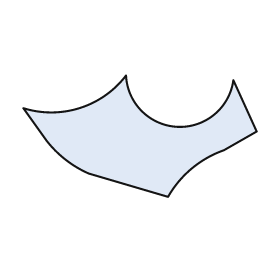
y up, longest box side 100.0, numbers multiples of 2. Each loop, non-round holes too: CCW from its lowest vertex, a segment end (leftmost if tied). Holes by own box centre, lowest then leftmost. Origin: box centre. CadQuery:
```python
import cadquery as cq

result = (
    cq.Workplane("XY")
    .moveTo(12.0, -26.0)
    .threePointArc((22.0, -14.0), (36.0, -6.0))
    .lineTo(50.0, 2.0)
    .lineTo(40.0, 24.0)
    .threePointArc((16.0, 4.0), (-6.0, 26.0))
    .threePointArc((-26.0, 12.0), (-50.0, 12.0))
    .lineTo(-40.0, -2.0)
    .threePointArc((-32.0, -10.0), (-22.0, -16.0))
    .close()
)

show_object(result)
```